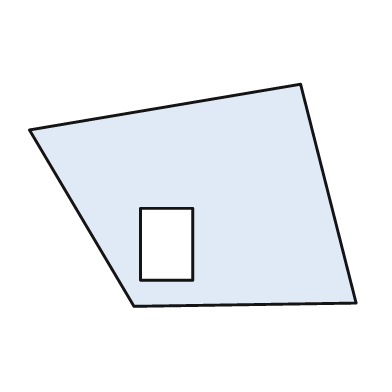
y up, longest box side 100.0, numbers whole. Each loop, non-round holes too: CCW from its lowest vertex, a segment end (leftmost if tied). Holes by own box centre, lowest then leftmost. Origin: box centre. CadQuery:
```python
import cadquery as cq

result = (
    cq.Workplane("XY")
    .moveTo(-18.0, -34.0)
    .lineTo(50.0, -33.0)
    .lineTo(33.0, 34.0)
    .lineTo(-50.0, 20.0)
    .close()
    .moveTo(-16.0, -26.0)
    .lineTo(0.0, -26.0)
    .lineTo(0.0, -4.0)
    .lineTo(-16.0, -4.0)
    .close()
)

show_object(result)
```